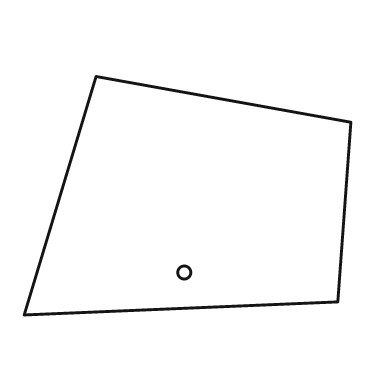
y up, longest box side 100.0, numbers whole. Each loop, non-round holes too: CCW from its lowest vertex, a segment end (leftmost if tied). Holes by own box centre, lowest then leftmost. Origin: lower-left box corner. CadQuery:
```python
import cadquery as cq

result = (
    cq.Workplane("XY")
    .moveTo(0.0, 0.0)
    .lineTo(96.0, 4.0)
    .lineTo(100.0, 59.0)
    .lineTo(22.0, 73.0)
    .close()
    .moveTo(49.0, 13.0)
    .circle(2.0)
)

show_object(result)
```